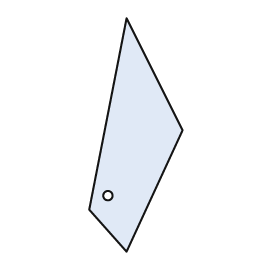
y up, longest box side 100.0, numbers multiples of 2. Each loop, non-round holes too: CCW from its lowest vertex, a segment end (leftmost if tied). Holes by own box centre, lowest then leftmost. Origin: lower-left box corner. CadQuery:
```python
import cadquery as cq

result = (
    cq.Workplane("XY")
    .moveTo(16.0, 0.0)
    .lineTo(40.0, 52.0)
    .lineTo(16.0, 100.0)
    .lineTo(0.0, 18.0)
    .close()
    .moveTo(8.0, 24.0)
    .circle(2.0)
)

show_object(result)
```